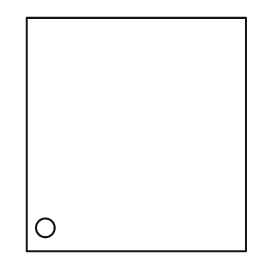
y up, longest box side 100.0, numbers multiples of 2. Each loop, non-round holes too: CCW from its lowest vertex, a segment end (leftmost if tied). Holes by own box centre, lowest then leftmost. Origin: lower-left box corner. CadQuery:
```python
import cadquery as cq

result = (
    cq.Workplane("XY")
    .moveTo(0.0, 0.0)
    .lineTo(94.0, 0.0)
    .lineTo(94.0, 100.0)
    .lineTo(0.0, 100.0)
    .close()
    .moveTo(8.0, 10.0)
    .circle(4.0)
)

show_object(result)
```